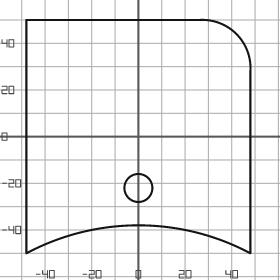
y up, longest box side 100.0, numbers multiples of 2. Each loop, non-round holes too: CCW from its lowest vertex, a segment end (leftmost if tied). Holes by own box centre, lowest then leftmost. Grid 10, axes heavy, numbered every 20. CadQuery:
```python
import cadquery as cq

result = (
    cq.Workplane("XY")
    .moveTo(-48.0, -50.0)
    .threePointArc((0.0, -38.0), (48.0, -50.0))
    .lineTo(48.0, 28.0)
    .threePointArc((42.0, 44.0), (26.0, 50.0))
    .lineTo(-48.0, 50.0)
    .close()
    .moveTo(0.0, -22.0)
    .circle(6.0)
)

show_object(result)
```